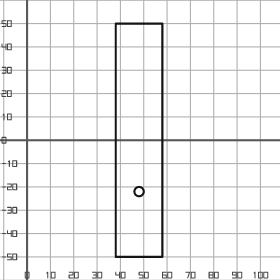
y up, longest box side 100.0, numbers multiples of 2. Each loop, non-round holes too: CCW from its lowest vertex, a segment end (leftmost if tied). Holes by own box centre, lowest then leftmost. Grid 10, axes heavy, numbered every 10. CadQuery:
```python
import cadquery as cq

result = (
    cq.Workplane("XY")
    .moveTo(38.0, -50.0)
    .lineTo(58.0, -50.0)
    .lineTo(58.0, 50.0)
    .lineTo(38.0, 50.0)
    .close()
    .moveTo(48.0, -22.0)
    .circle(2.0)
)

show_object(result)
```